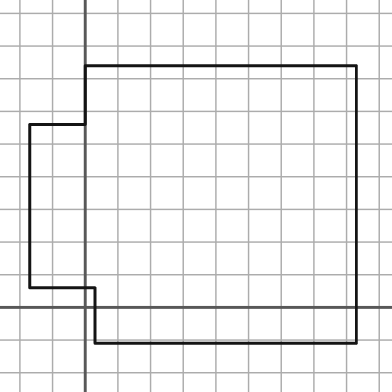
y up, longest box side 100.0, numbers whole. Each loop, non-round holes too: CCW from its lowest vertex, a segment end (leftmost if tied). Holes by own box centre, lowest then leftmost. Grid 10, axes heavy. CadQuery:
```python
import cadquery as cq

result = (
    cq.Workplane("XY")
    .moveTo(3.0, -11.0)
    .lineTo(83.0, -11.0)
    .lineTo(83.0, 74.0)
    .lineTo(0.0, 74.0)
    .lineTo(0.0, 56.0)
    .lineTo(-17.0, 56.0)
    .lineTo(-17.0, 6.0)
    .lineTo(3.0, 6.0)
    .close()
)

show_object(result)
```